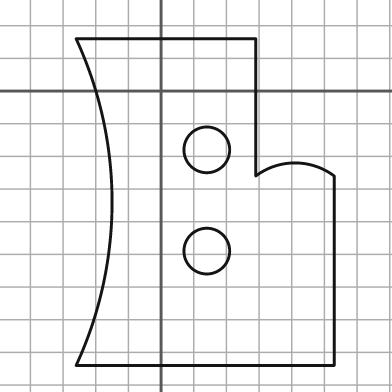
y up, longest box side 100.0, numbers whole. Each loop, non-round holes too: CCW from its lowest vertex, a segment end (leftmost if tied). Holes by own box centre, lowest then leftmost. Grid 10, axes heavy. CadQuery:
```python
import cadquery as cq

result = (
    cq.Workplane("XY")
    .moveTo(-26.0, -84.0)
    .lineTo(53.0, -84.0)
    .lineTo(53.0, -26.0)
    .threePointArc((41.0, -22.0), (29.0, -26.0))
    .lineTo(29.0, 16.0)
    .lineTo(-26.0, 16.0)
    .threePointArc((-15.0, -34.0), (-26.0, -84.0))
    .close()
    .moveTo(14.0, -49.0)
    .circle(7.0)
    .moveTo(14.0, -18.0)
    .circle(7.0)
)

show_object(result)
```